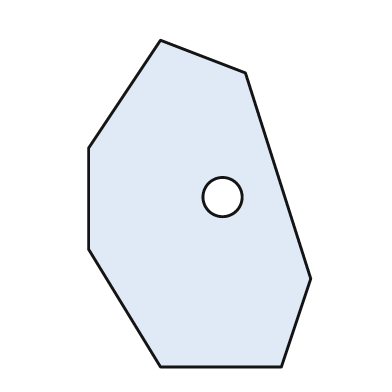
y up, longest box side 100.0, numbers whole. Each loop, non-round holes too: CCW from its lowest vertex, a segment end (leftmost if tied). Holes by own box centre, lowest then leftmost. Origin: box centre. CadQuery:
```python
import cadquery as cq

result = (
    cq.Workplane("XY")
    .moveTo(-12.0, -50.0)
    .lineTo(25.0, -50.0)
    .lineTo(34.0, -23.0)
    .lineTo(14.0, 40.0)
    .lineTo(-12.0, 50.0)
    .lineTo(-34.0, 17.0)
    .lineTo(-34.0, -14.0)
    .close()
    .moveTo(7.0, 2.0)
    .circle(6.0)
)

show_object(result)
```